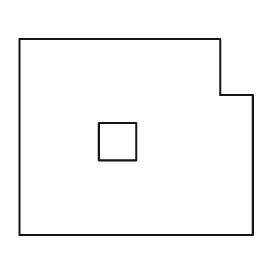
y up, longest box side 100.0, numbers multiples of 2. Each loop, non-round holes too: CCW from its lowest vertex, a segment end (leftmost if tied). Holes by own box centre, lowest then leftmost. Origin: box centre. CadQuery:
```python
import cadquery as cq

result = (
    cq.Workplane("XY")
    .moveTo(-50.0, -42.0)
    .lineTo(50.0, -42.0)
    .lineTo(50.0, 18.0)
    .lineTo(36.0, 18.0)
    .lineTo(36.0, 42.0)
    .lineTo(-50.0, 42.0)
    .close()
    .moveTo(-16.0, -10.0)
    .lineTo(0.0, -10.0)
    .lineTo(0.0, 6.0)
    .lineTo(-16.0, 6.0)
    .close()
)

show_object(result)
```